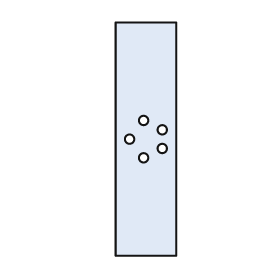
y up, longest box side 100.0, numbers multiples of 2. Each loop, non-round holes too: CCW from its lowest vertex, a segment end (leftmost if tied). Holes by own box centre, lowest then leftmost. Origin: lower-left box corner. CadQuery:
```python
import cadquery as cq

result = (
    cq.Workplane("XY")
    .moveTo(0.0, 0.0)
    .lineTo(26.0, 0.0)
    .lineTo(26.0, 100.0)
    .lineTo(0.0, 100.0)
    .close()
    .moveTo(12.0, 42.0)
    .circle(2.0)
    .moveTo(20.0, 46.0)
    .circle(2.0)
    .moveTo(6.0, 50.0)
    .circle(2.0)
    .moveTo(20.0, 54.0)
    .circle(2.0)
    .moveTo(12.0, 58.0)
    .circle(2.0)
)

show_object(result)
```